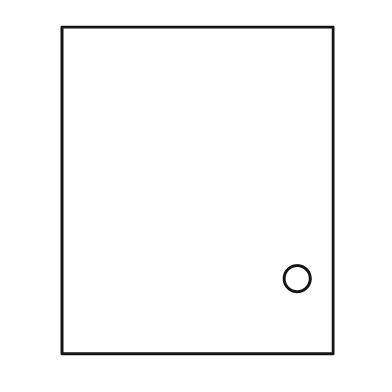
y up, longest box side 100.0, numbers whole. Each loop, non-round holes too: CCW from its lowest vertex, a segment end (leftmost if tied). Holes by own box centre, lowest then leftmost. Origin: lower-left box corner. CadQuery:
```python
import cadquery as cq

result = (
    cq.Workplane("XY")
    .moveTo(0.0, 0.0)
    .lineTo(83.0, 0.0)
    .lineTo(83.0, 100.0)
    .lineTo(0.0, 100.0)
    .close()
    .moveTo(72.0, 23.0)
    .circle(4.0)
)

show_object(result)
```